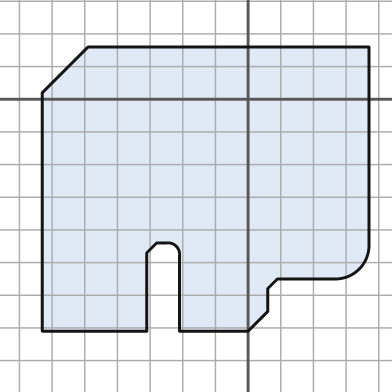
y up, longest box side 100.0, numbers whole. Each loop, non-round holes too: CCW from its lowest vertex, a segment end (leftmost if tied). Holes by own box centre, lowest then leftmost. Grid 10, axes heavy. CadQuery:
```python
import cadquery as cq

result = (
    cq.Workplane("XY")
    .moveTo(-63.0, -71.0)
    .lineTo(-31.0, -71.0)
    .lineTo(-31.0, -47.0)
    .lineTo(-28.0, -44.0)
    .lineTo(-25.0, -44.0)
    .threePointArc((-22.0, -45.0), (-21.0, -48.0))
    .lineTo(-21.0, -71.0)
    .lineTo(0.0, -71.0)
    .lineTo(6.0, -65.0)
    .lineTo(6.0, -58.0)
    .lineTo(9.0, -55.0)
    .lineTo(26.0, -55.0)
    .threePointArc((34.0, -52.0), (37.0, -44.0))
    .lineTo(37.0, 16.0)
    .lineTo(-49.0, 16.0)
    .lineTo(-63.0, 2.0)
    .close()
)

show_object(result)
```